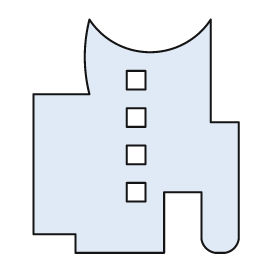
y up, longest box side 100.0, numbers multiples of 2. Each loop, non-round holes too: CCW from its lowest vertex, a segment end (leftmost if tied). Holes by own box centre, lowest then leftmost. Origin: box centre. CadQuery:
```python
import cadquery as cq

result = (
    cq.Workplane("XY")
    .moveTo(-26.0, -50.0)
    .lineTo(12.0, -50.0)
    .lineTo(12.0, -24.0)
    .lineTo(28.0, -24.0)
    .lineTo(28.0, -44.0)
    .threePointArc((30.0, -48.0), (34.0, -50.0))
    .lineTo(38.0, -50.0)
    .threePointArc((42.0, -48.0), (44.0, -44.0))
    .lineTo(44.0, 6.0)
    .lineTo(32.0, 6.0)
    .lineTo(32.0, 50.0)
    .threePointArc((6.0, 36.0), (-20.0, 50.0))
    .threePointArc((-22.0, 34.0), (-20.0, 18.0))
    .lineTo(-44.0, 18.0)
    .lineTo(-44.0, -42.0)
    .lineTo(-26.0, -42.0)
    .close()
    .moveTo(-4.0, -28.0)
    .lineTo(4.0, -28.0)
    .lineTo(4.0, -20.0)
    .lineTo(-4.0, -20.0)
    .close()
    .moveTo(-4.0, -12.0)
    .lineTo(4.0, -12.0)
    .lineTo(4.0, -4.0)
    .lineTo(-4.0, -4.0)
    .close()
    .moveTo(-4.0, 4.0)
    .lineTo(4.0, 4.0)
    .lineTo(4.0, 12.0)
    .lineTo(-4.0, 12.0)
    .close()
    .moveTo(-4.0, 20.0)
    .lineTo(4.0, 20.0)
    .lineTo(4.0, 28.0)
    .lineTo(-4.0, 28.0)
    .close()
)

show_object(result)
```